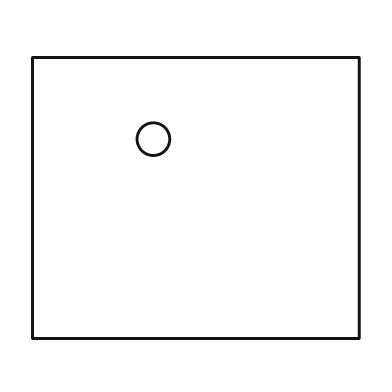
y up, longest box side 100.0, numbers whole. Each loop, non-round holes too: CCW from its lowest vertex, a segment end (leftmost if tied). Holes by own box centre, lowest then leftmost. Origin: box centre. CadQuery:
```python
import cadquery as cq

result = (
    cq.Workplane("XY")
    .moveTo(-50.0, -43.0)
    .lineTo(50.0, -43.0)
    .lineTo(50.0, 43.0)
    .lineTo(-50.0, 43.0)
    .close()
    .moveTo(-13.0, 18.0)
    .circle(5.0)
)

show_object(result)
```